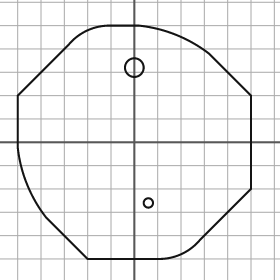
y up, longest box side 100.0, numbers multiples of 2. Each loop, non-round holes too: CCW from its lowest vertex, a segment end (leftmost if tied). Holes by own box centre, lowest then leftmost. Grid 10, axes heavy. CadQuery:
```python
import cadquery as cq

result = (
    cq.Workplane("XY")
    .moveTo(-20.0, -50.0)
    .lineTo(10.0, -50.0)
    .threePointArc((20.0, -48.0), (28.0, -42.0))
    .lineTo(50.0, -20.0)
    .lineTo(50.0, 20.0)
    .lineTo(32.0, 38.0)
    .threePointArc((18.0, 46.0), (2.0, 50.0))
    .lineTo(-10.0, 50.0)
    .threePointArc((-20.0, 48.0), (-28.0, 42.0))
    .lineTo(-50.0, 20.0)
    .lineTo(-50.0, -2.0)
    .threePointArc((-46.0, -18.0), (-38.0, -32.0))
    .close()
    .moveTo(6.0, -26.0)
    .circle(2.0)
    .moveTo(0.0, 32.0)
    .circle(4.0)
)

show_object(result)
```